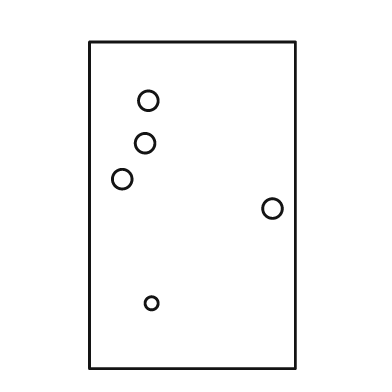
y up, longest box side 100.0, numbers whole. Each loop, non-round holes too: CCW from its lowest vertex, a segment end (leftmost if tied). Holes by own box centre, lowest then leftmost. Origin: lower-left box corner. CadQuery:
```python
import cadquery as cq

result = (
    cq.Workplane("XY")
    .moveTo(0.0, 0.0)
    .lineTo(63.0, 0.0)
    .lineTo(63.0, 100.0)
    .lineTo(0.0, 100.0)
    .close()
    .moveTo(19.0, 20.0)
    .circle(2.0)
    .moveTo(56.0, 49.0)
    .circle(3.0)
    .moveTo(10.0, 58.0)
    .circle(3.0)
    .moveTo(17.0, 69.0)
    .circle(3.0)
    .moveTo(18.0, 82.0)
    .circle(3.0)
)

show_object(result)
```